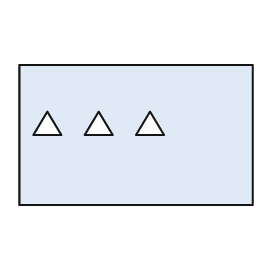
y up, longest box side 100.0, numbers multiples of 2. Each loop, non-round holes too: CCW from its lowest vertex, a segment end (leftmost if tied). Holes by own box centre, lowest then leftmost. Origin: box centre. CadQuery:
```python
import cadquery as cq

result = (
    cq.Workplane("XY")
    .moveTo(-50.0, -30.0)
    .lineTo(50.0, -30.0)
    .lineTo(50.0, 30.0)
    .lineTo(-50.0, 30.0)
    .close()
    .moveTo(-44.0, 0.0)
    .lineTo(-32.0, 0.0)
    .lineTo(-38.0, 10.0)
    .close()
    .moveTo(-22.0, 0.0)
    .lineTo(-10.0, 0.0)
    .lineTo(-16.0, 10.0)
    .close()
    .moveTo(0.0, 0.0)
    .lineTo(12.0, 0.0)
    .lineTo(6.0, 10.0)
    .close()
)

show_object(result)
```